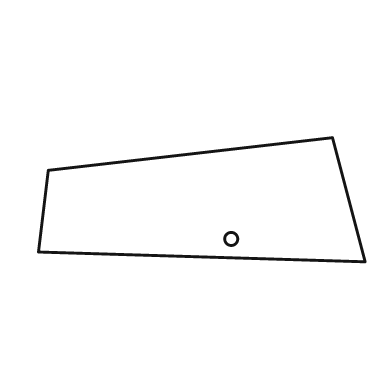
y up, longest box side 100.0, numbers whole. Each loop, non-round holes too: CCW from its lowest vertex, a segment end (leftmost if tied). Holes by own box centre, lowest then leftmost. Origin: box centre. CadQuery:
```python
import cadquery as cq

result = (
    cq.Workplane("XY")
    .moveTo(50.0, -19.0)
    .lineTo(40.0, 19.0)
    .lineTo(-47.0, 9.0)
    .lineTo(-50.0, -16.0)
    .close()
    .moveTo(9.0, -12.0)
    .circle(2.0)
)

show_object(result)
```